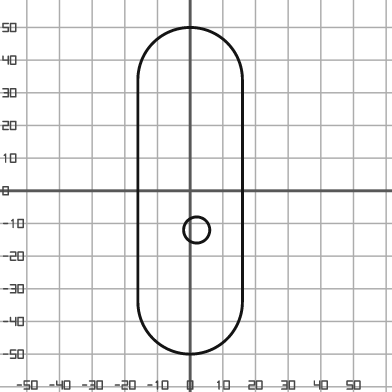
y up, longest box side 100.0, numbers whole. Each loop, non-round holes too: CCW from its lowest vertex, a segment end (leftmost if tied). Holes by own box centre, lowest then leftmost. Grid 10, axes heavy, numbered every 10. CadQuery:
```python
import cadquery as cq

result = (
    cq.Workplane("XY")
    .moveTo(-16.0, -34.0)
    .threePointArc((0.0, -50.0), (16.0, -34.0))
    .lineTo(16.0, 34.0)
    .threePointArc((0.0, 50.0), (-16.0, 34.0))
    .close()
    .moveTo(2.0, -12.0)
    .circle(4.0)
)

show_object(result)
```